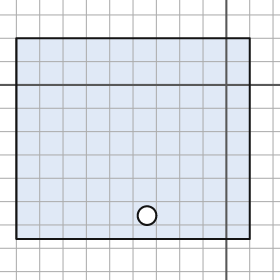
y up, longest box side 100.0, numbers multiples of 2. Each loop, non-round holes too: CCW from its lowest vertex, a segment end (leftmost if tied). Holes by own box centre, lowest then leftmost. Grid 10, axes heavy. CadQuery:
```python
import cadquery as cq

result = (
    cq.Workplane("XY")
    .moveTo(-90.0, -66.0)
    .lineTo(10.0, -66.0)
    .lineTo(10.0, 20.0)
    .lineTo(-90.0, 20.0)
    .close()
    .moveTo(-34.0, -56.0)
    .circle(4.0)
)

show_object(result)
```